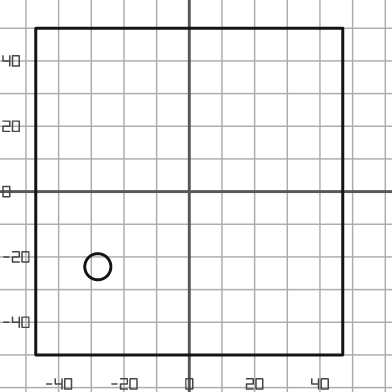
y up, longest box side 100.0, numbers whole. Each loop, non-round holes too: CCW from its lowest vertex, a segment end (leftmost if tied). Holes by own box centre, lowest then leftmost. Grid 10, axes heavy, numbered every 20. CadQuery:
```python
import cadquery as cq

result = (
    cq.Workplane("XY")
    .moveTo(-47.0, -50.0)
    .lineTo(47.0, -50.0)
    .lineTo(47.0, 50.0)
    .lineTo(-47.0, 50.0)
    .close()
    .moveTo(-28.0, -23.0)
    .circle(4.0)
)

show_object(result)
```